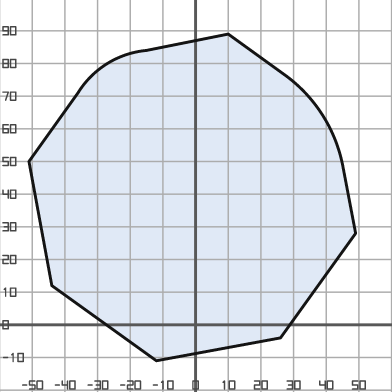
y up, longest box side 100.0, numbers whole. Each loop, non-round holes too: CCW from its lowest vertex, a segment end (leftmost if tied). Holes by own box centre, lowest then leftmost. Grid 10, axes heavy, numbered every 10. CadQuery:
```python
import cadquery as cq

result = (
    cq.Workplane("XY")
    .moveTo(-12.0, -11.0)
    .lineTo(26.0, -4.0)
    .lineTo(49.0, 28.0)
    .lineTo(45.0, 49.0)
    .threePointArc((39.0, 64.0), (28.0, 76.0))
    .lineTo(10.0, 89.0)
    .lineTo(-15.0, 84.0)
    .threePointArc((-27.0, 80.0), (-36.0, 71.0))
    .lineTo(-51.0, 50.0)
    .lineTo(-44.0, 12.0)
    .close()
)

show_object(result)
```